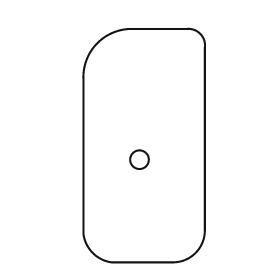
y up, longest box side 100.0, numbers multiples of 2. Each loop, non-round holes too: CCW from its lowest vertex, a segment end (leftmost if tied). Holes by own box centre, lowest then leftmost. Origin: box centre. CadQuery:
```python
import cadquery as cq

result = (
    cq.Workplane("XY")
    .moveTo(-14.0, -50.0)
    .lineTo(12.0, -50.0)
    .threePointArc((22.0, -46.0), (26.0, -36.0))
    .lineTo(26.0, 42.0)
    .threePointArc((24.0, 48.0), (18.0, 50.0))
    .lineTo(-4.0, 50.0)
    .threePointArc((-20.0, 44.0), (-26.0, 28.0))
    .lineTo(-26.0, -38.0)
    .threePointArc((-22.0, -46.0), (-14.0, -50.0))
    .close()
    .moveTo(-2.0, -6.0)
    .circle(4.0)
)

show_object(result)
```